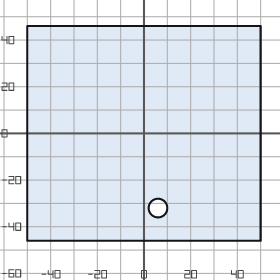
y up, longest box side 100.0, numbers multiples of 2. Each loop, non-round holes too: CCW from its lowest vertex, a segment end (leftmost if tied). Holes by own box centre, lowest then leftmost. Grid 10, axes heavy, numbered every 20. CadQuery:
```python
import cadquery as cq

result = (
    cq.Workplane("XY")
    .moveTo(-50.0, -46.0)
    .lineTo(50.0, -46.0)
    .lineTo(50.0, 46.0)
    .lineTo(-50.0, 46.0)
    .close()
    .moveTo(6.0, -32.0)
    .circle(4.0)
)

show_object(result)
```